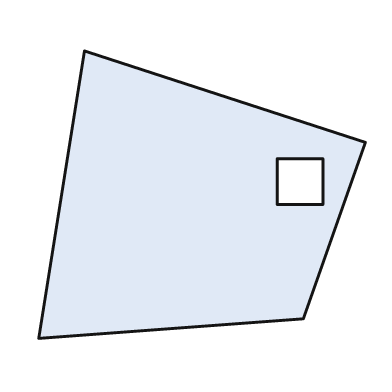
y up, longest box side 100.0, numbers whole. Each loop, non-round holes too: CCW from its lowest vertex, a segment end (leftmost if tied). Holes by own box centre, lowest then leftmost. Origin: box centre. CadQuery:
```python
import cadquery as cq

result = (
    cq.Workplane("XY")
    .moveTo(-50.0, -44.0)
    .lineTo(31.0, -38.0)
    .lineTo(50.0, 16.0)
    .lineTo(-36.0, 44.0)
    .close()
    .moveTo(23.0, -3.0)
    .lineTo(37.0, -3.0)
    .lineTo(37.0, 11.0)
    .lineTo(23.0, 11.0)
    .close()
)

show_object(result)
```